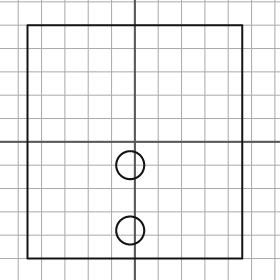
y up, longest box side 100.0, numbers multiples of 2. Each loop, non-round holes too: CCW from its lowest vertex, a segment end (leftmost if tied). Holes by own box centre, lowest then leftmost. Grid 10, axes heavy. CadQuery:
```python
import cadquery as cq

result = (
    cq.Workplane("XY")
    .moveTo(-46.0, -50.0)
    .lineTo(46.0, -50.0)
    .lineTo(46.0, 50.0)
    .lineTo(-46.0, 50.0)
    .close()
    .moveTo(-2.0, -38.0)
    .circle(6.0)
    .moveTo(-2.0, -10.0)
    .circle(6.0)
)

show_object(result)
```